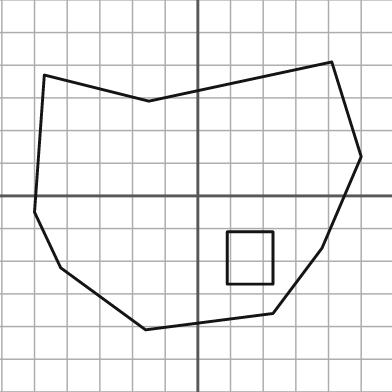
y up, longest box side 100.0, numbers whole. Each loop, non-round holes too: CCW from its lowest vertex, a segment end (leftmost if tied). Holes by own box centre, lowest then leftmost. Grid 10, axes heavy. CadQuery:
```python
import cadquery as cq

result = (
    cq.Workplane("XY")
    .moveTo(-16.0, -41.0)
    .lineTo(23.0, -36.0)
    .lineTo(38.0, -16.0)
    .lineTo(50.0, 12.0)
    .lineTo(41.0, 41.0)
    .lineTo(-15.0, 29.0)
    .lineTo(-47.0, 37.0)
    .lineTo(-50.0, -5.0)
    .lineTo(-42.0, -22.0)
    .close()
    .moveTo(9.0, -27.0)
    .lineTo(23.0, -27.0)
    .lineTo(23.0, -11.0)
    .lineTo(9.0, -11.0)
    .close()
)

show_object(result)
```